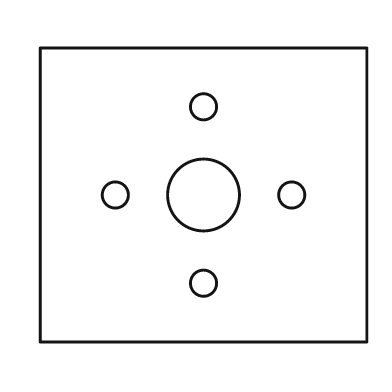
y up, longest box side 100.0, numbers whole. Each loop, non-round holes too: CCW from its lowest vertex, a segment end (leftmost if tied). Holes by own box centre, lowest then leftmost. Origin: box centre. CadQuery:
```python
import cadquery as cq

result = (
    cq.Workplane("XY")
    .moveTo(-50.0, -45.0)
    .lineTo(50.0, -45.0)
    .lineTo(50.0, 45.0)
    .lineTo(-50.0, 45.0)
    .close()
    .moveTo(0.0, -27.0)
    .circle(4.0)
    .moveTo(-27.0, 0.0)
    .circle(4.0)
    .moveTo(0.0, 0.0)
    .circle(11.0)
    .moveTo(27.0, 0.0)
    .circle(4.0)
    .moveTo(0.0, 27.0)
    .circle(4.0)
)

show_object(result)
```